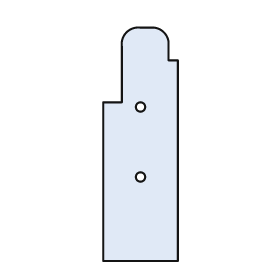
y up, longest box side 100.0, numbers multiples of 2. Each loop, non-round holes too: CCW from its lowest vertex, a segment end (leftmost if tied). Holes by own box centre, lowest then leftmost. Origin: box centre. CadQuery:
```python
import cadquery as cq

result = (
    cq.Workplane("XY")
    .moveTo(-16.0, -50.0)
    .lineTo(16.0, -50.0)
    .lineTo(16.0, 36.0)
    .lineTo(12.0, 36.0)
    .lineTo(12.0, 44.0)
    .threePointArc((10.0, 48.0), (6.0, 50.0))
    .lineTo(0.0, 50.0)
    .threePointArc((-6.0, 48.0), (-8.0, 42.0))
    .lineTo(-8.0, 18.0)
    .lineTo(-16.0, 18.0)
    .close()
    .moveTo(0.0, -14.0)
    .circle(2.0)
    .moveTo(0.0, 16.0)
    .circle(2.0)
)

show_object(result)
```